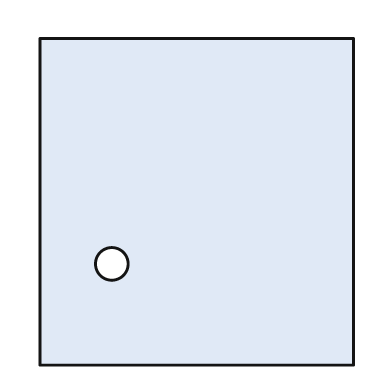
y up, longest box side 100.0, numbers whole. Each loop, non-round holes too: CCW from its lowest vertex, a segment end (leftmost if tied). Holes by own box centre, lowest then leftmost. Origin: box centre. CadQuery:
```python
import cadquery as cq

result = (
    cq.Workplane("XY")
    .moveTo(-48.0, -50.0)
    .lineTo(48.0, -50.0)
    .lineTo(48.0, 50.0)
    .lineTo(-48.0, 50.0)
    .close()
    .moveTo(-26.0, -19.0)
    .circle(5.0)
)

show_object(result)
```